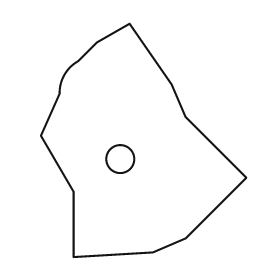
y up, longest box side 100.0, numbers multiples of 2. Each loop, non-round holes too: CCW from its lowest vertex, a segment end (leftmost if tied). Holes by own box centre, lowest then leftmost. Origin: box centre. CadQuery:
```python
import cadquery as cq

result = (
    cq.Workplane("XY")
    .moveTo(-30.0, -50.0)
    .lineTo(4.0, -48.0)
    .lineTo(18.0, -42.0)
    .lineTo(44.0, -16.0)
    .lineTo(18.0, 10.0)
    .lineTo(12.0, 24.0)
    .lineTo(-6.0, 50.0)
    .lineTo(-20.0, 42.0)
    .lineTo(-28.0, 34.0)
    .threePointArc((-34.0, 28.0), (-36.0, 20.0))
    .lineTo(-44.0, 2.0)
    .lineTo(-30.0, -22.0)
    .close()
    .moveTo(-10.0, -8.0)
    .circle(6.0)
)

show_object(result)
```